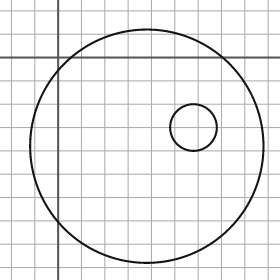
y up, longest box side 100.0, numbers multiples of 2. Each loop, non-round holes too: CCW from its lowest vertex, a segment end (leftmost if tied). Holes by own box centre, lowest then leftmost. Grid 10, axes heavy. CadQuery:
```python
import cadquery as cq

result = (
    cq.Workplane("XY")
    .moveTo(38.0, -38.0)
    .circle(50.0)
    .moveTo(58.0, -30.0)
    .circle(10.0)
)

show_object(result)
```